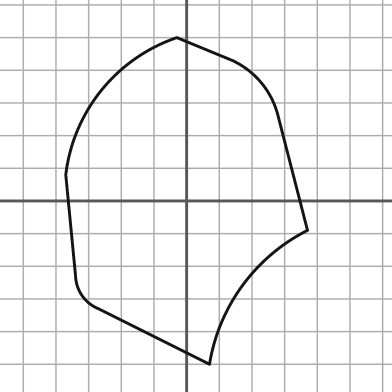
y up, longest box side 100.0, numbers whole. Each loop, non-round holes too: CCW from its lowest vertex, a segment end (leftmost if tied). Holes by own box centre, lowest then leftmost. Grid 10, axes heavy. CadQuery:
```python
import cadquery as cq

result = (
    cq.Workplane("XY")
    .moveTo(7.0, -50.0)
    .threePointArc((17.0, -26.0), (37.0, -9.0))
    .lineTo(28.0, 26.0)
    .threePointArc((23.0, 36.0), (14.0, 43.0))
    .lineTo(-3.0, 50.0)
    .threePointArc((-26.0, 34.0), (-37.0, 8.0))
    .lineTo(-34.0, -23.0)
    .threePointArc((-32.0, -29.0), (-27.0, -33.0))
    .close()
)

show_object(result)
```